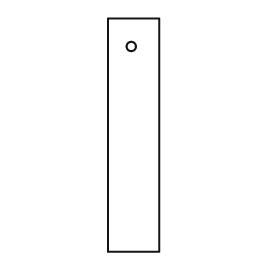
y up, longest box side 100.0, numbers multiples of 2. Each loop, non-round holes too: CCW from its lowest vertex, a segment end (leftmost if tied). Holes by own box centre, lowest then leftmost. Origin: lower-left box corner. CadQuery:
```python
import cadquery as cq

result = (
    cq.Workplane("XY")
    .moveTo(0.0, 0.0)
    .lineTo(22.0, 0.0)
    .lineTo(22.0, 100.0)
    .lineTo(0.0, 100.0)
    .close()
    .moveTo(10.0, 88.0)
    .circle(2.0)
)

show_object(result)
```